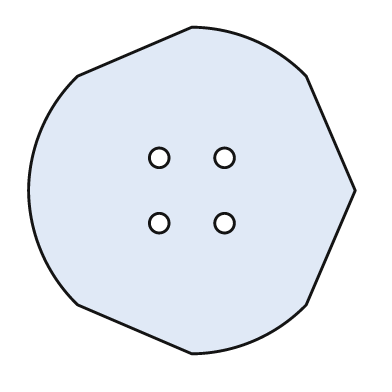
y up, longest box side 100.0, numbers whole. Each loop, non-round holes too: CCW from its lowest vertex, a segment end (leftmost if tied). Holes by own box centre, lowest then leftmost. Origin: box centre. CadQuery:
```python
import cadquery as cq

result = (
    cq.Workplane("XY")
    .moveTo(0.0, -50.0)
    .threePointArc((19.0, -46.0), (35.0, -35.0))
    .lineTo(50.0, 0.0)
    .lineTo(35.0, 35.0)
    .threePointArc((19.0, 46.0), (0.0, 50.0))
    .lineTo(-35.0, 35.0)
    .threePointArc((-46.0, 19.0), (-50.0, 0.0))
    .threePointArc((-46.0, -19.0), (-35.0, -35.0))
    .close()
    .moveTo(-10.0, -10.0)
    .circle(3.0)
    .moveTo(10.0, -10.0)
    .circle(3.0)
    .moveTo(-10.0, 10.0)
    .circle(3.0)
    .moveTo(10.0, 10.0)
    .circle(3.0)
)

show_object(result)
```